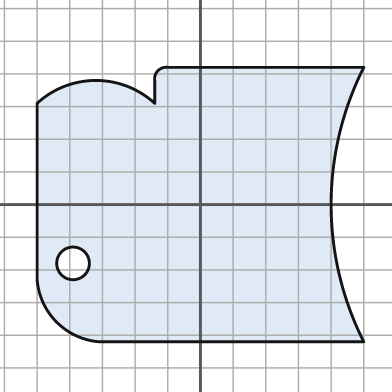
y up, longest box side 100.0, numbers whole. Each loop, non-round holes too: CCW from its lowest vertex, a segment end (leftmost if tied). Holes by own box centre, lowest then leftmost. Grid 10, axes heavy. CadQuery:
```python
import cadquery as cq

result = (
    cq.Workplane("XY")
    .moveTo(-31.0, -42.0)
    .lineTo(50.0, -42.0)
    .threePointArc((40.0, 0.0), (50.0, 42.0))
    .lineTo(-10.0, 42.0)
    .threePointArc((-13.0, 41.0), (-14.0, 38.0))
    .lineTo(-14.0, 31.0)
    .threePointArc((-32.0, 38.0), (-50.0, 31.0))
    .lineTo(-50.0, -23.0)
    .threePointArc((-44.0, -36.0), (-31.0, -42.0))
    .close()
    .moveTo(-39.0, -18.0)
    .circle(5.0)
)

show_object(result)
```